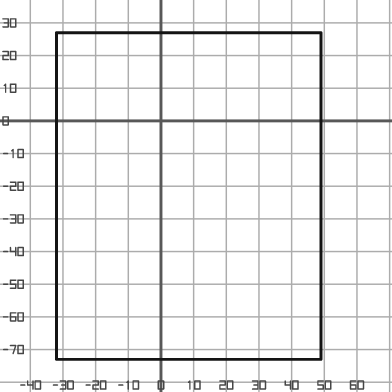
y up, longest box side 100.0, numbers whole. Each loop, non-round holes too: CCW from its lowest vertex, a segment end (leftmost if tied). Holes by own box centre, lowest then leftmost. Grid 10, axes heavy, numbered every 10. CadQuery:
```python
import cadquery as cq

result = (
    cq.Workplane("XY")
    .moveTo(-32.0, -73.0)
    .lineTo(49.0, -73.0)
    .lineTo(49.0, 27.0)
    .lineTo(-32.0, 27.0)
    .close()
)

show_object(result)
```